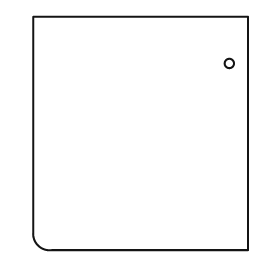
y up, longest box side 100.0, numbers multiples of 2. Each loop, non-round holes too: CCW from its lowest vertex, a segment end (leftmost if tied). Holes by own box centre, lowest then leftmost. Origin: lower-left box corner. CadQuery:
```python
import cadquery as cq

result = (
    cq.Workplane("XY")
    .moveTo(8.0, 0.0)
    .lineTo(92.0, 0.0)
    .lineTo(92.0, 100.0)
    .lineTo(0.0, 100.0)
    .lineTo(0.0, 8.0)
    .threePointArc((2.0, 2.0), (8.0, 0.0))
    .close()
    .moveTo(84.0, 80.0)
    .circle(2.0)
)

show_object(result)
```